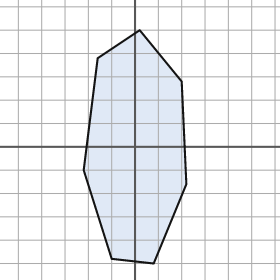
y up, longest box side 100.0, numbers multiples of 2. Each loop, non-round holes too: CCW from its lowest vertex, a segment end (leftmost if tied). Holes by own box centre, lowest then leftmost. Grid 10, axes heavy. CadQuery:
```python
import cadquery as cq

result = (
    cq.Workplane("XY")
    .moveTo(8.0, -50.0)
    .lineTo(22.0, -16.0)
    .lineTo(20.0, 28.0)
    .lineTo(2.0, 50.0)
    .lineTo(-16.0, 38.0)
    .lineTo(-22.0, -10.0)
    .lineTo(-10.0, -48.0)
    .close()
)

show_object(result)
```